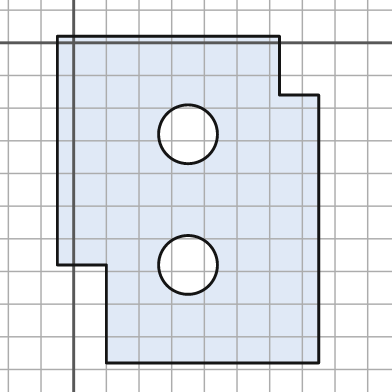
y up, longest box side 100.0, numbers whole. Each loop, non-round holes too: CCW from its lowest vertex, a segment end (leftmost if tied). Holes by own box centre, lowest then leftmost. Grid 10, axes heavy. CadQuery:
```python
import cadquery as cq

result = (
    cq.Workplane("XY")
    .moveTo(10.0, -98.0)
    .lineTo(75.0, -98.0)
    .lineTo(75.0, -16.0)
    .lineTo(63.0, -16.0)
    .lineTo(63.0, 2.0)
    .lineTo(-5.0, 2.0)
    .lineTo(-5.0, -68.0)
    .lineTo(10.0, -68.0)
    .close()
    .moveTo(35.0, -68.0)
    .circle(9.0)
    .moveTo(35.0, -28.0)
    .circle(9.0)
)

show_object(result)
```